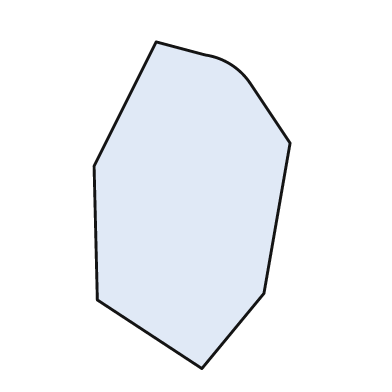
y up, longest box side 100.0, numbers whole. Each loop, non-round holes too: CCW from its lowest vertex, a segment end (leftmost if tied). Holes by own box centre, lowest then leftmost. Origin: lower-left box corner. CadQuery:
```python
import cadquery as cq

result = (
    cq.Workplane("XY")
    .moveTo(33.0, 0.0)
    .lineTo(52.0, 23.0)
    .lineTo(60.0, 69.0)
    .lineTo(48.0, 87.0)
    .threePointArc((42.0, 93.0), (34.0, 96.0))
    .lineTo(19.0, 100.0)
    .lineTo(0.0, 62.0)
    .lineTo(1.0, 21.0)
    .close()
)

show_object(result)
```